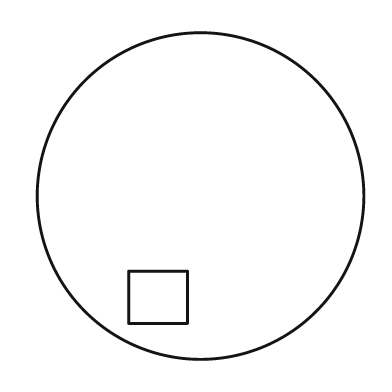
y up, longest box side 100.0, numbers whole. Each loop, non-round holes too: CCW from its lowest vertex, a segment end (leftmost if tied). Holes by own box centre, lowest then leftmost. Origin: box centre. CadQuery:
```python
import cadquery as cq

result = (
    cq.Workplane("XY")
    .moveTo(0.0, 0.0)
    .circle(50.0)
    .moveTo(-22.0, -39.0)
    .lineTo(-4.0, -39.0)
    .lineTo(-4.0, -23.0)
    .lineTo(-22.0, -23.0)
    .close()
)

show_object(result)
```